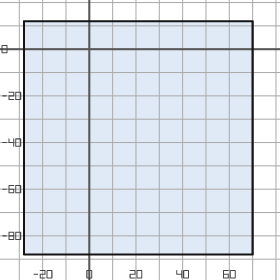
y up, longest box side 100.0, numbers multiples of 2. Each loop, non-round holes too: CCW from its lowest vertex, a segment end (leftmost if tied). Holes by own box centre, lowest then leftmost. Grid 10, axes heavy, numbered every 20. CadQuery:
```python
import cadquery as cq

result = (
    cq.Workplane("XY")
    .moveTo(-28.0, -88.0)
    .lineTo(70.0, -88.0)
    .lineTo(70.0, 12.0)
    .lineTo(-28.0, 12.0)
    .close()
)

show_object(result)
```